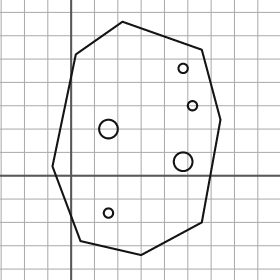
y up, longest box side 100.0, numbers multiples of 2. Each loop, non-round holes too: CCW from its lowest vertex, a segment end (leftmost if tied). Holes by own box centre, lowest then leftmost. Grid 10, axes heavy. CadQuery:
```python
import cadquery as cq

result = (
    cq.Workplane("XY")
    .moveTo(30.0, -34.0)
    .lineTo(56.0, -20.0)
    .lineTo(64.0, 24.0)
    .lineTo(56.0, 54.0)
    .lineTo(22.0, 66.0)
    .lineTo(2.0, 52.0)
    .lineTo(-8.0, 4.0)
    .lineTo(4.0, -28.0)
    .close()
    .moveTo(16.0, -16.0)
    .circle(2.0)
    .moveTo(48.0, 6.0)
    .circle(4.0)
    .moveTo(16.0, 20.0)
    .circle(4.0)
    .moveTo(52.0, 30.0)
    .circle(2.0)
    .moveTo(48.0, 46.0)
    .circle(2.0)
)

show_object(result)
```